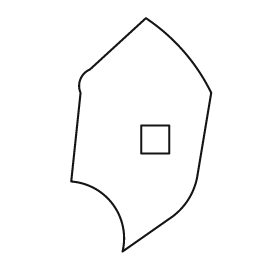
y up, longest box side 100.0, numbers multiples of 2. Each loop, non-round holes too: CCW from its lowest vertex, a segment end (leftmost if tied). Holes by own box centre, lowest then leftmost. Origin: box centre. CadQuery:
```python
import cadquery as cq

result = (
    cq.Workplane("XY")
    .moveTo(-8.0, -50.0)
    .lineTo(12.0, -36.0)
    .threePointArc((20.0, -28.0), (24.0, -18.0))
    .lineTo(30.0, 18.0)
    .threePointArc((18.0, 36.0), (2.0, 50.0))
    .lineTo(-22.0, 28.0)
    .threePointArc((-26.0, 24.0), (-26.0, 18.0))
    .lineTo(-30.0, -20.0)
    .threePointArc((-12.0, -30.0), (-8.0, -50.0))
    .close()
    .moveTo(0.0, -8.0)
    .lineTo(12.0, -8.0)
    .lineTo(12.0, 4.0)
    .lineTo(0.0, 4.0)
    .close()
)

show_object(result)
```